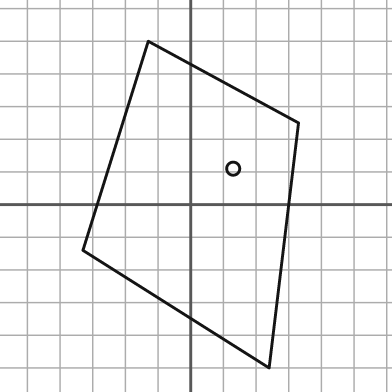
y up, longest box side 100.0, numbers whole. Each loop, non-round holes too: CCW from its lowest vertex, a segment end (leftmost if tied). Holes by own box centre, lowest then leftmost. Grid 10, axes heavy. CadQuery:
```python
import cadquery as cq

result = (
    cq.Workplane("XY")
    .moveTo(24.0, -50.0)
    .lineTo(33.0, 25.0)
    .lineTo(-13.0, 50.0)
    .lineTo(-33.0, -14.0)
    .close()
    .moveTo(13.0, 11.0)
    .circle(2.0)
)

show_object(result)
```